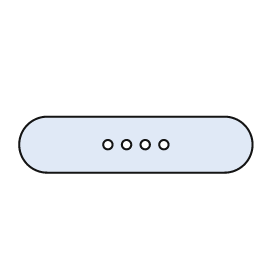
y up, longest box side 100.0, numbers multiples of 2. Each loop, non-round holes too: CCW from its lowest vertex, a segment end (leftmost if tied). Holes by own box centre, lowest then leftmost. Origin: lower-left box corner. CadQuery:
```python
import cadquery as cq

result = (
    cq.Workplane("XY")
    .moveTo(12.0, 0.0)
    .lineTo(88.0, 0.0)
    .threePointArc((100.0, 12.0), (88.0, 24.0))
    .lineTo(12.0, 24.0)
    .threePointArc((0.0, 12.0), (12.0, 0.0))
    .close()
    .moveTo(38.0, 12.0)
    .circle(2.0)
    .moveTo(46.0, 12.0)
    .circle(2.0)
    .moveTo(54.0, 12.0)
    .circle(2.0)
    .moveTo(62.0, 12.0)
    .circle(2.0)
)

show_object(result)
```